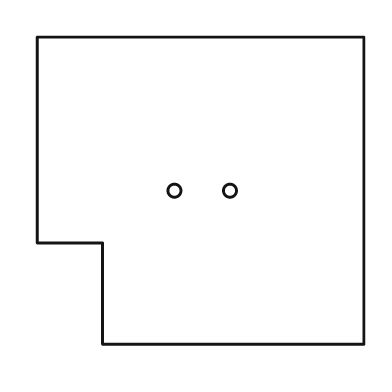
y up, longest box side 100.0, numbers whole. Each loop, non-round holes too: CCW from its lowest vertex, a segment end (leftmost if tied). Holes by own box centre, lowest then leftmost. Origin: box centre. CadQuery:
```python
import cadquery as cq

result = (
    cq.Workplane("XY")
    .moveTo(-30.0, -47.0)
    .lineTo(50.0, -47.0)
    .lineTo(50.0, 47.0)
    .lineTo(-50.0, 47.0)
    .lineTo(-50.0, -16.0)
    .lineTo(-30.0, -16.0)
    .close()
    .moveTo(-8.0, 0.0)
    .circle(2.0)
    .moveTo(9.0, 0.0)
    .circle(2.0)
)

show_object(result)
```